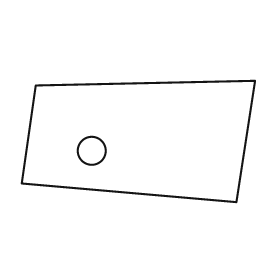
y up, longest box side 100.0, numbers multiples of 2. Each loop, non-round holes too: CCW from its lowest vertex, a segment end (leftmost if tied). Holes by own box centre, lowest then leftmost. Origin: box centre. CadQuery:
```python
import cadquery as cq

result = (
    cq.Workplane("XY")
    .moveTo(42.0, -26.0)
    .lineTo(50.0, 26.0)
    .lineTo(-44.0, 24.0)
    .lineTo(-50.0, -18.0)
    .close()
    .moveTo(-20.0, -4.0)
    .circle(6.0)
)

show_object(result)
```